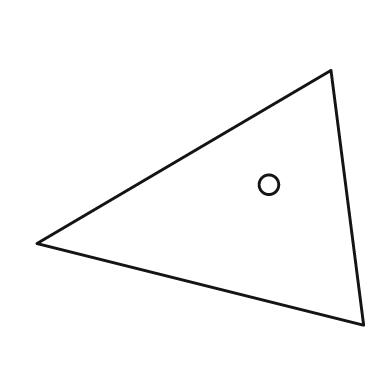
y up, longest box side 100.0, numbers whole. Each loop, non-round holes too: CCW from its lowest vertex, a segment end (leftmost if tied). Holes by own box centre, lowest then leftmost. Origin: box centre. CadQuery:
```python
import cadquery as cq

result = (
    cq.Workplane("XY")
    .moveTo(50.0, -39.0)
    .lineTo(40.0, 39.0)
    .lineTo(-50.0, -14.0)
    .close()
    .moveTo(21.0, 4.0)
    .circle(3.0)
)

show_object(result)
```